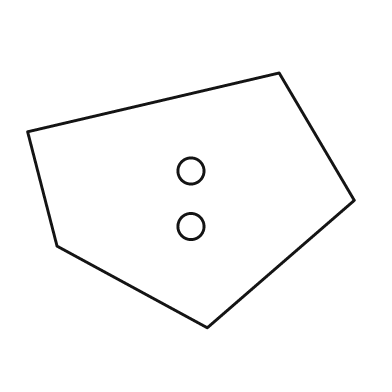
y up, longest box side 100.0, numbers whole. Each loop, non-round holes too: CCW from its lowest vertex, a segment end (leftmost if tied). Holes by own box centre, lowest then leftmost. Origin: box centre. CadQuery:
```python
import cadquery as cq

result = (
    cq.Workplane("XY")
    .moveTo(5.0, -39.0)
    .lineTo(50.0, 0.0)
    .lineTo(27.0, 39.0)
    .lineTo(-50.0, 21.0)
    .lineTo(-41.0, -14.0)
    .close()
    .moveTo(0.0, -8.0)
    .circle(4.0)
    .moveTo(0.0, 9.0)
    .circle(4.0)
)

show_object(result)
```